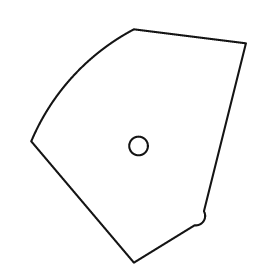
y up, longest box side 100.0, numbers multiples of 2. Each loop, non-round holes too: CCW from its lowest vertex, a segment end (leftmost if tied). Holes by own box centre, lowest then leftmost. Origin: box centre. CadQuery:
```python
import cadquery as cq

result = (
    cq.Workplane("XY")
    .moveTo(-2.0, -50.0)
    .lineTo(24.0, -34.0)
    .threePointArc((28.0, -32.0), (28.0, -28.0))
    .lineTo(46.0, 44.0)
    .lineTo(-2.0, 50.0)
    .threePointArc((-28.0, 30.0), (-46.0, 2.0))
    .close()
    .moveTo(0.0, 0.0)
    .circle(4.0)
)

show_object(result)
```